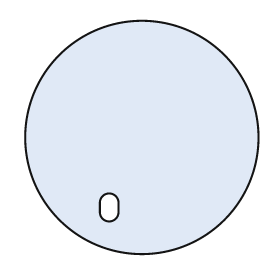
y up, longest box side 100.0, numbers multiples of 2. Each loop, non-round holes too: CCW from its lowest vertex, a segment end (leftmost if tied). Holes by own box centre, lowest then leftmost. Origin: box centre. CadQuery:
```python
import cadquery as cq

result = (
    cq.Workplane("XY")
    .moveTo(0.0, 0.0)
    .circle(50.0)
    .moveTo(-18.0, -32.0)
    .threePointArc((-14.0, -36.0), (-10.0, -32.0))
    .lineTo(-10.0, -28.0)
    .threePointArc((-14.0, -24.0), (-18.0, -28.0))
    .close()
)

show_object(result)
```